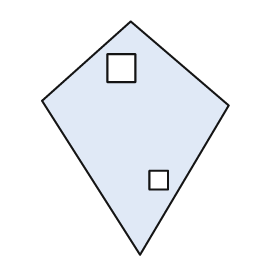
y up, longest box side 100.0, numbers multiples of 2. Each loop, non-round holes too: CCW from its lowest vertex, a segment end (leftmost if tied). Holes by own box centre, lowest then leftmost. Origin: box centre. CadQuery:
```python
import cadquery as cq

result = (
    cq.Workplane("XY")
    .moveTo(2.0, -50.0)
    .lineTo(40.0, 14.0)
    .lineTo(-2.0, 50.0)
    .lineTo(-40.0, 16.0)
    .close()
    .moveTo(6.0, -22.0)
    .lineTo(14.0, -22.0)
    .lineTo(14.0, -14.0)
    .lineTo(6.0, -14.0)
    .close()
    .moveTo(-12.0, 24.0)
    .lineTo(0.0, 24.0)
    .lineTo(0.0, 36.0)
    .lineTo(-12.0, 36.0)
    .close()
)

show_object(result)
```